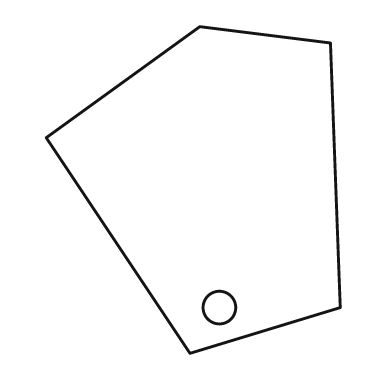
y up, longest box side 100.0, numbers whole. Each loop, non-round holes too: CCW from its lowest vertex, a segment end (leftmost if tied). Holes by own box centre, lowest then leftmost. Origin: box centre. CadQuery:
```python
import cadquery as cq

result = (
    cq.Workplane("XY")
    .moveTo(-1.0, -50.0)
    .lineTo(45.0, -36.0)
    .lineTo(42.0, 45.0)
    .lineTo(2.0, 50.0)
    .lineTo(-45.0, 16.0)
    .close()
    .moveTo(8.0, -36.0)
    .circle(5.0)
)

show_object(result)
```